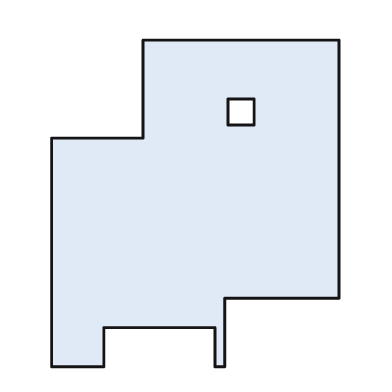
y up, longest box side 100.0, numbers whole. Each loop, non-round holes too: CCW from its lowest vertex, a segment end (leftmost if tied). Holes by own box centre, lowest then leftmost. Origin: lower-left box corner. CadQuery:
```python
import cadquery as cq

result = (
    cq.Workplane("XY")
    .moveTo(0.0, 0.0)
    .lineTo(16.0, 0.0)
    .lineTo(16.0, 12.0)
    .lineTo(50.0, 12.0)
    .lineTo(50.0, 0.0)
    .lineTo(53.0, 0.0)
    .lineTo(53.0, 21.0)
    .lineTo(88.0, 21.0)
    .lineTo(88.0, 100.0)
    .lineTo(28.0, 100.0)
    .lineTo(28.0, 70.0)
    .lineTo(0.0, 70.0)
    .close()
    .moveTo(54.0, 74.0)
    .lineTo(62.0, 74.0)
    .lineTo(62.0, 82.0)
    .lineTo(54.0, 82.0)
    .close()
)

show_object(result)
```